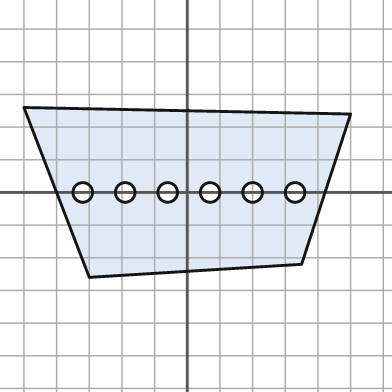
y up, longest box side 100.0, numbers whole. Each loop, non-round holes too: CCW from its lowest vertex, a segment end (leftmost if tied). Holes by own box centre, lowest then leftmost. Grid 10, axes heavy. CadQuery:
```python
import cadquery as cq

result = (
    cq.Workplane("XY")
    .moveTo(-30.0, -26.0)
    .lineTo(35.0, -22.0)
    .lineTo(50.0, 24.0)
    .lineTo(-50.0, 26.0)
    .close()
    .moveTo(-32.0, 0.0)
    .circle(3.0)
    .moveTo(-19.0, 0.0)
    .circle(3.0)
    .moveTo(-6.0, 0.0)
    .circle(3.0)
    .moveTo(7.0, 0.0)
    .circle(3.0)
    .moveTo(20.0, 0.0)
    .circle(3.0)
    .moveTo(33.0, 0.0)
    .circle(3.0)
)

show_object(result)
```